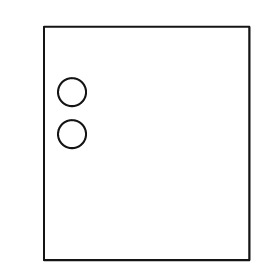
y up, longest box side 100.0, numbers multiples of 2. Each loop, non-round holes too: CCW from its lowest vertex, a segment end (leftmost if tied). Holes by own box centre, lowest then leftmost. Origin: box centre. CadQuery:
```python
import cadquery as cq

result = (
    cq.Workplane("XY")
    .moveTo(-44.0, -50.0)
    .lineTo(44.0, -50.0)
    .lineTo(44.0, 50.0)
    .lineTo(-44.0, 50.0)
    .close()
    .moveTo(-32.0, 4.0)
    .circle(6.0)
    .moveTo(-32.0, 22.0)
    .circle(6.0)
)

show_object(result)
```